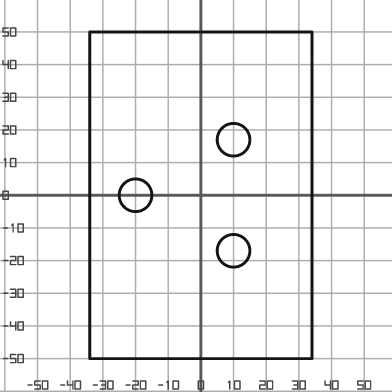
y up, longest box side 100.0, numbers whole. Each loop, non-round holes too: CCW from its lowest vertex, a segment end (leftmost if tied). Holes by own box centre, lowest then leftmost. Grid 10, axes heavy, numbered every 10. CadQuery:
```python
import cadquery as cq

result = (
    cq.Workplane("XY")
    .moveTo(-34.0, -50.0)
    .lineTo(34.0, -50.0)
    .lineTo(34.0, 50.0)
    .lineTo(-34.0, 50.0)
    .close()
    .moveTo(10.0, -17.0)
    .circle(5.0)
    .moveTo(-20.0, 0.0)
    .circle(5.0)
    .moveTo(10.0, 17.0)
    .circle(5.0)
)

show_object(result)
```